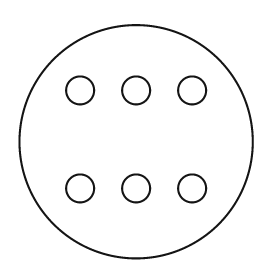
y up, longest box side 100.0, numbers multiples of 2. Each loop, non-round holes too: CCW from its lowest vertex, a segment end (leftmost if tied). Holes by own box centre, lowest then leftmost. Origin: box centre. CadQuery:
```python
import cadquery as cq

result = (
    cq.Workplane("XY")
    .moveTo(0.0, 0.0)
    .circle(50.0)
    .moveTo(-24.0, -20.0)
    .circle(6.0)
    .moveTo(0.0, -20.0)
    .circle(6.0)
    .moveTo(24.0, -20.0)
    .circle(6.0)
    .moveTo(-24.0, 22.0)
    .circle(6.0)
    .moveTo(0.0, 22.0)
    .circle(6.0)
    .moveTo(24.0, 22.0)
    .circle(6.0)
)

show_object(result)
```